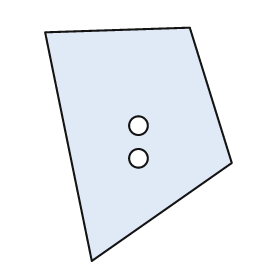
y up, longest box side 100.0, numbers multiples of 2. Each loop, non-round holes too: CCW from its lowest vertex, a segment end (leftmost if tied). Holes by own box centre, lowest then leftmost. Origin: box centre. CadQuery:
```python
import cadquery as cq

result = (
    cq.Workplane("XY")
    .moveTo(-20.0, -50.0)
    .lineTo(40.0, -8.0)
    .lineTo(22.0, 50.0)
    .lineTo(-40.0, 48.0)
    .close()
    .moveTo(0.0, -6.0)
    .circle(4.0)
    .moveTo(0.0, 8.0)
    .circle(4.0)
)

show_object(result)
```